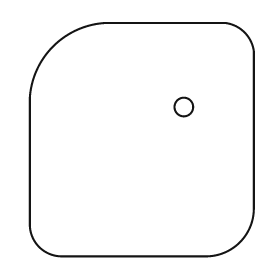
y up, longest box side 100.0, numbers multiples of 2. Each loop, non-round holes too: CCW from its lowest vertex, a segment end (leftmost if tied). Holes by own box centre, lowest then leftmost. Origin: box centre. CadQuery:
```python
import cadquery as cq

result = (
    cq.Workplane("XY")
    .moveTo(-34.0, -50.0)
    .lineTo(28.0, -50.0)
    .threePointArc((42.0, -44.0), (48.0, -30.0))
    .lineTo(48.0, 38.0)
    .threePointArc((44.0, 46.0), (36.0, 50.0))
    .lineTo(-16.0, 50.0)
    .threePointArc((-38.0, 40.0), (-48.0, 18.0))
    .lineTo(-48.0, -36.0)
    .threePointArc((-44.0, -46.0), (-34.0, -50.0))
    .close()
    .moveTo(18.0, 14.0)
    .circle(4.0)
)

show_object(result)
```